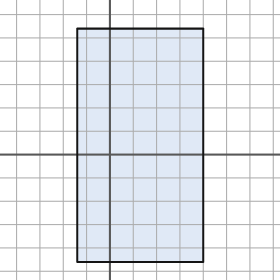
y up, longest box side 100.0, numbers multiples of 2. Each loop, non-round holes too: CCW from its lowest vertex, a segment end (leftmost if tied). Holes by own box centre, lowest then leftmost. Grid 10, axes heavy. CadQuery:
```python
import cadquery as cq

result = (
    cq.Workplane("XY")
    .moveTo(-14.0, -46.0)
    .lineTo(40.0, -46.0)
    .lineTo(40.0, 54.0)
    .lineTo(-14.0, 54.0)
    .close()
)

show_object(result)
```